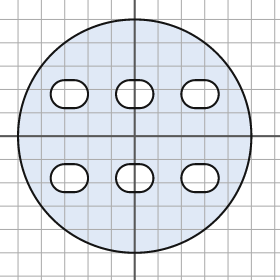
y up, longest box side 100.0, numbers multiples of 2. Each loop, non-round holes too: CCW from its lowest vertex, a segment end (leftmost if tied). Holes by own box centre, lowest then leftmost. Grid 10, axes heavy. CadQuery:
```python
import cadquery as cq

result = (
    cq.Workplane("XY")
    .moveTo(0.0, 0.0)
    .circle(50.0)
    .moveTo(-30.0, -24.0)
    .lineTo(-26.0, -24.0)
    .threePointArc((-20.0, -18.0), (-26.0, -12.0))
    .lineTo(-30.0, -12.0)
    .threePointArc((-36.0, -18.0), (-30.0, -24.0))
    .close()
    .moveTo(-2.0, -24.0)
    .lineTo(2.0, -24.0)
    .threePointArc((8.0, -18.0), (2.0, -12.0))
    .lineTo(-2.0, -12.0)
    .threePointArc((-8.0, -18.0), (-2.0, -24.0))
    .close()
    .moveTo(26.0, -24.0)
    .lineTo(30.0, -24.0)
    .threePointArc((36.0, -18.0), (30.0, -12.0))
    .lineTo(26.0, -12.0)
    .threePointArc((20.0, -18.0), (26.0, -24.0))
    .close()
    .moveTo(-30.0, 12.0)
    .lineTo(-26.0, 12.0)
    .threePointArc((-20.0, 18.0), (-26.0, 24.0))
    .lineTo(-30.0, 24.0)
    .threePointArc((-36.0, 18.0), (-30.0, 12.0))
    .close()
    .moveTo(-2.0, 12.0)
    .lineTo(2.0, 12.0)
    .threePointArc((8.0, 18.0), (2.0, 24.0))
    .lineTo(-2.0, 24.0)
    .threePointArc((-8.0, 18.0), (-2.0, 12.0))
    .close()
    .moveTo(26.0, 12.0)
    .lineTo(30.0, 12.0)
    .threePointArc((36.0, 18.0), (30.0, 24.0))
    .lineTo(26.0, 24.0)
    .threePointArc((20.0, 18.0), (26.0, 12.0))
    .close()
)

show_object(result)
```